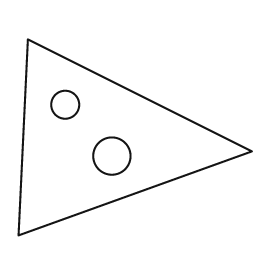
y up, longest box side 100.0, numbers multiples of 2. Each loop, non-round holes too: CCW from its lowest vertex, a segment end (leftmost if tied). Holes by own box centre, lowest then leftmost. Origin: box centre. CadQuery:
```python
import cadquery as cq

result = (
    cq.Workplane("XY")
    .moveTo(-50.0, -42.0)
    .lineTo(50.0, -6.0)
    .lineTo(-46.0, 42.0)
    .close()
    .moveTo(-10.0, -8.0)
    .circle(8.0)
    .moveTo(-30.0, 14.0)
    .circle(6.0)
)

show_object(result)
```